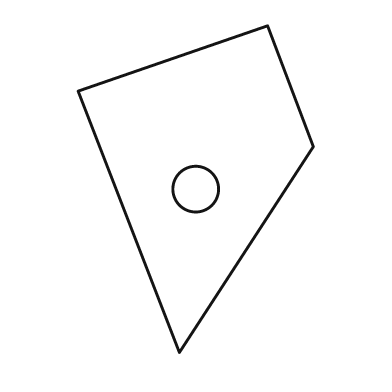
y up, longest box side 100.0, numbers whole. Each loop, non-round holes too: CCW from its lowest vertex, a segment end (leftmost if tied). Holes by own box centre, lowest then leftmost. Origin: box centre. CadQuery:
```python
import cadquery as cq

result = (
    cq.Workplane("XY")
    .moveTo(-5.0, -50.0)
    .lineTo(36.0, 13.0)
    .lineTo(22.0, 50.0)
    .lineTo(-36.0, 30.0)
    .close()
    .moveTo(0.0, 0.0)
    .circle(7.0)
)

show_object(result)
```